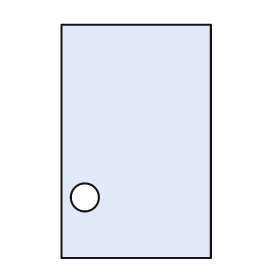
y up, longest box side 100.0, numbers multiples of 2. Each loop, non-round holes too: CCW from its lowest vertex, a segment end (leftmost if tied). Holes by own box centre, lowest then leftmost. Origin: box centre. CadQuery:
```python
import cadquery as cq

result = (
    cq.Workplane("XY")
    .moveTo(-32.0, -50.0)
    .lineTo(32.0, -50.0)
    .lineTo(32.0, 50.0)
    .lineTo(-32.0, 50.0)
    .close()
    .moveTo(-22.0, -24.0)
    .circle(6.0)
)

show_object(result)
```